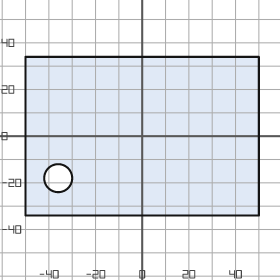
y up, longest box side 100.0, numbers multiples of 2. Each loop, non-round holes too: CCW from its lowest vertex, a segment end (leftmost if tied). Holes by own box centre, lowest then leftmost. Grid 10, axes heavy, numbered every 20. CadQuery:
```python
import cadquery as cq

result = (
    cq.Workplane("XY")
    .moveTo(-50.0, -34.0)
    .lineTo(50.0, -34.0)
    .lineTo(50.0, 34.0)
    .lineTo(-50.0, 34.0)
    .close()
    .moveTo(-36.0, -18.0)
    .circle(6.0)
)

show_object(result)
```